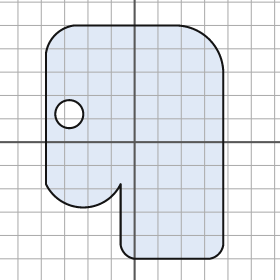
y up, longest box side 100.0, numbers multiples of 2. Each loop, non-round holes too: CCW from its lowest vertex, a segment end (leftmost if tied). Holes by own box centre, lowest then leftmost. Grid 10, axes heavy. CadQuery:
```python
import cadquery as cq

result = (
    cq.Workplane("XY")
    .moveTo(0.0, -50.0)
    .lineTo(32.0, -50.0)
    .threePointArc((36.0, -48.0), (38.0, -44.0))
    .lineTo(38.0, 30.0)
    .threePointArc((32.0, 44.0), (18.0, 50.0))
    .lineTo(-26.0, 50.0)
    .threePointArc((-34.0, 46.0), (-38.0, 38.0))
    .lineTo(-38.0, -18.0)
    .threePointArc((-22.0, -28.0), (-6.0, -18.0))
    .lineTo(-6.0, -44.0)
    .threePointArc((-4.0, -48.0), (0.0, -50.0))
    .close()
    .moveTo(-28.0, 12.0)
    .circle(6.0)
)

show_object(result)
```